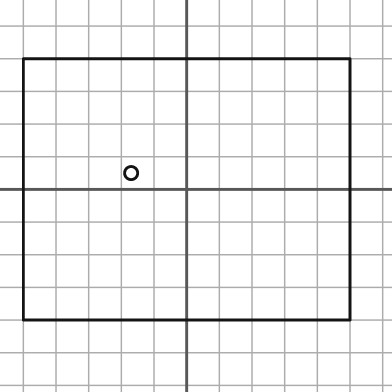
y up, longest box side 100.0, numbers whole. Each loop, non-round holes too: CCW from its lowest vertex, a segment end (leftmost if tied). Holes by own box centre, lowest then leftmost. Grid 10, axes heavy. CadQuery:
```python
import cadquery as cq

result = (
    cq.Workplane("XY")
    .moveTo(-50.0, -40.0)
    .lineTo(50.0, -40.0)
    .lineTo(50.0, 40.0)
    .lineTo(-50.0, 40.0)
    .close()
    .moveTo(-17.0, 5.0)
    .circle(2.0)
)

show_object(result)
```